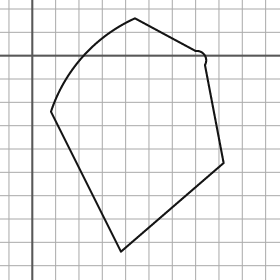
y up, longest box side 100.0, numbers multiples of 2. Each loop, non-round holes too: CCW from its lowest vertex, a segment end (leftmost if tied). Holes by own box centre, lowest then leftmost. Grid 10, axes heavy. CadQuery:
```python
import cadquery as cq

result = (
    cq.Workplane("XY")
    .moveTo(38.0, -84.0)
    .lineTo(82.0, -46.0)
    .lineTo(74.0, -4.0)
    .threePointArc((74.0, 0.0), (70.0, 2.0))
    .lineTo(44.0, 16.0)
    .threePointArc((22.0, 0.0), (8.0, -24.0))
    .close()
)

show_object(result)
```